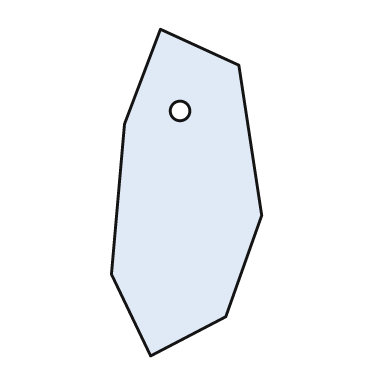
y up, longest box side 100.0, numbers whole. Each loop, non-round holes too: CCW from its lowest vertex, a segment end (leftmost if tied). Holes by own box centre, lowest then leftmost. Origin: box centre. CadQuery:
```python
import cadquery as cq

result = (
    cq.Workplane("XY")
    .moveTo(-11.0, -50.0)
    .lineTo(12.0, -38.0)
    .lineTo(23.0, -7.0)
    .lineTo(16.0, 39.0)
    .lineTo(-8.0, 50.0)
    .lineTo(-19.0, 21.0)
    .lineTo(-23.0, -25.0)
    .close()
    .moveTo(-2.0, 25.0)
    .circle(3.0)
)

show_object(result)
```